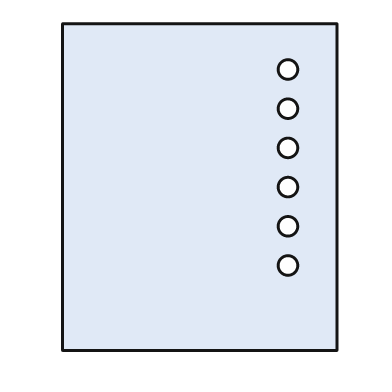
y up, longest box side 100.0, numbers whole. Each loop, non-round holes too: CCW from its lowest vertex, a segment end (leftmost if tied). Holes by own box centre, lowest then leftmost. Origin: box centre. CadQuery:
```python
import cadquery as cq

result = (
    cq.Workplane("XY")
    .moveTo(-42.0, -50.0)
    .lineTo(42.0, -50.0)
    .lineTo(42.0, 50.0)
    .lineTo(-42.0, 50.0)
    .close()
    .moveTo(27.0, -24.0)
    .circle(3.0)
    .moveTo(27.0, -12.0)
    .circle(3.0)
    .moveTo(27.0, 0.0)
    .circle(3.0)
    .moveTo(27.0, 12.0)
    .circle(3.0)
    .moveTo(27.0, 24.0)
    .circle(3.0)
    .moveTo(27.0, 36.0)
    .circle(3.0)
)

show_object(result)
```